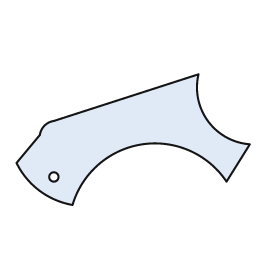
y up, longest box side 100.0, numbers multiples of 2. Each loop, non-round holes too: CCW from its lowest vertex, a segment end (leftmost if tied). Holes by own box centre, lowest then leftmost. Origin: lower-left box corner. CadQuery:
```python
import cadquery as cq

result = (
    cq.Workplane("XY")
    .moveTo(24.0, 0.0)
    .threePointArc((54.0, 26.0), (90.0, 10.0))
    .lineTo(100.0, 26.0)
    .threePointArc((82.0, 36.0), (78.0, 56.0))
    .lineTo(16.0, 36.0)
    .threePointArc((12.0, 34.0), (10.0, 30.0))
    .lineTo(0.0, 18.0)
    .threePointArc((10.0, 6.0), (24.0, 0.0))
    .close()
    .moveTo(16.0, 12.0)
    .circle(2.0)
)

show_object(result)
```